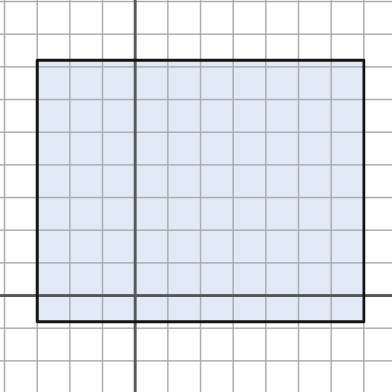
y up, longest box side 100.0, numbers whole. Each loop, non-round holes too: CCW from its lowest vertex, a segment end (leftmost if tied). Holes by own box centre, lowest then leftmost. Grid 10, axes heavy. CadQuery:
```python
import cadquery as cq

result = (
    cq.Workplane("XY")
    .moveTo(-30.0, -8.0)
    .lineTo(70.0, -8.0)
    .lineTo(70.0, 72.0)
    .lineTo(-30.0, 72.0)
    .close()
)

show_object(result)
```